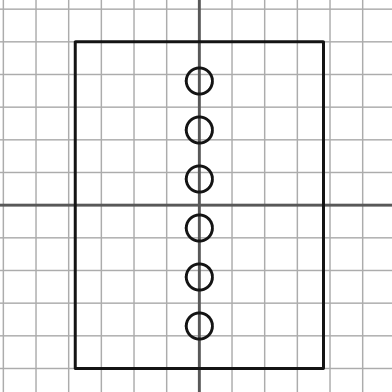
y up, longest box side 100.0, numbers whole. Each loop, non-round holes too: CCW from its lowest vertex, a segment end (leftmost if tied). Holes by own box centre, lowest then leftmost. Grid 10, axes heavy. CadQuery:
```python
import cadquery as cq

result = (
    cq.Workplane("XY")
    .moveTo(-38.0, -50.0)
    .lineTo(38.0, -50.0)
    .lineTo(38.0, 50.0)
    .lineTo(-38.0, 50.0)
    .close()
    .moveTo(0.0, -37.0)
    .circle(4.0)
    .moveTo(0.0, -22.0)
    .circle(4.0)
    .moveTo(0.0, -7.0)
    .circle(4.0)
    .moveTo(0.0, 8.0)
    .circle(4.0)
    .moveTo(0.0, 23.0)
    .circle(4.0)
    .moveTo(0.0, 38.0)
    .circle(4.0)
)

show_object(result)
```